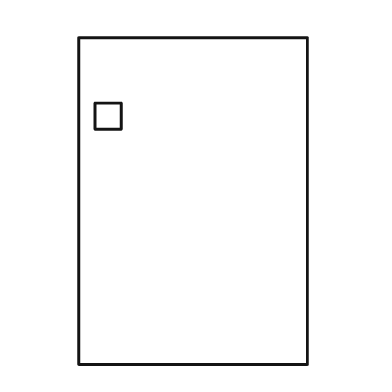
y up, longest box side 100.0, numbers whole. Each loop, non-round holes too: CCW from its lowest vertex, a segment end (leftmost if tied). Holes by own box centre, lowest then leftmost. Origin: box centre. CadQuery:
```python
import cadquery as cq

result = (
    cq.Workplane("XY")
    .moveTo(-35.0, -50.0)
    .lineTo(35.0, -50.0)
    .lineTo(35.0, 50.0)
    .lineTo(-35.0, 50.0)
    .close()
    .moveTo(-30.0, 22.0)
    .lineTo(-22.0, 22.0)
    .lineTo(-22.0, 30.0)
    .lineTo(-30.0, 30.0)
    .close()
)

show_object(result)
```